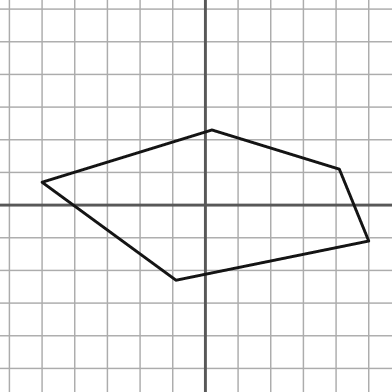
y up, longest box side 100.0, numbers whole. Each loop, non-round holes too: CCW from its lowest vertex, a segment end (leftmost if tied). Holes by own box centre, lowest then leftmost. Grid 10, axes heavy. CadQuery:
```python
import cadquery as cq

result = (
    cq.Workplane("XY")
    .moveTo(-9.0, -23.0)
    .lineTo(50.0, -11.0)
    .lineTo(41.0, 11.0)
    .lineTo(2.0, 23.0)
    .lineTo(-50.0, 7.0)
    .close()
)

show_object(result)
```